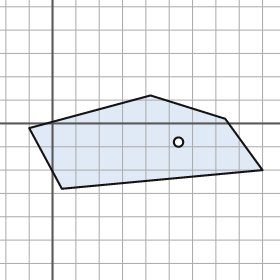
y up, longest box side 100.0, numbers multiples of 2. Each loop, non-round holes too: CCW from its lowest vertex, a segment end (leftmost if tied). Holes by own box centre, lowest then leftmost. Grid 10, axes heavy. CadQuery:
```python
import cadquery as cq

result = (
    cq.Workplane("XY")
    .moveTo(4.0, -28.0)
    .lineTo(90.0, -20.0)
    .lineTo(74.0, 2.0)
    .lineTo(42.0, 12.0)
    .lineTo(-10.0, -2.0)
    .close()
    .moveTo(54.0, -8.0)
    .circle(2.0)
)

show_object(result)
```